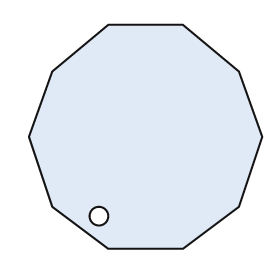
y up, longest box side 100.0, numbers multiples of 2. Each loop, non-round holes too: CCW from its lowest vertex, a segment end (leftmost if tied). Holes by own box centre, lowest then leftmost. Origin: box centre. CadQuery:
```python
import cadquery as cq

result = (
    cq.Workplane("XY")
    .moveTo(-16.0, -48.0)
    .lineTo(16.0, -48.0)
    .lineTo(40.0, -30.0)
    .lineTo(50.0, 0.0)
    .lineTo(40.0, 28.0)
    .lineTo(16.0, 48.0)
    .lineTo(-16.0, 48.0)
    .lineTo(-40.0, 28.0)
    .lineTo(-50.0, 0.0)
    .lineTo(-40.0, -30.0)
    .close()
    .moveTo(-20.0, -34.0)
    .circle(4.0)
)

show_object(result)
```